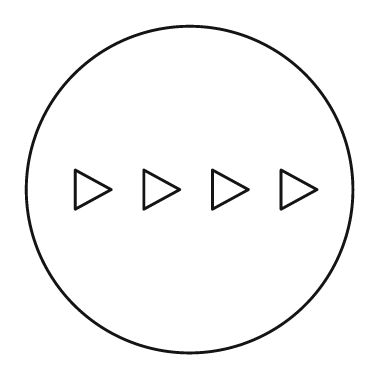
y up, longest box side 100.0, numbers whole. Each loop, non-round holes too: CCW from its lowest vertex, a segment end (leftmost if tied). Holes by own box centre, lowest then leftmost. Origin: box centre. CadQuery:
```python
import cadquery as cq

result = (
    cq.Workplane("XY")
    .moveTo(0.0, 0.0)
    .circle(50.0)
    .moveTo(-35.0, -6.0)
    .lineTo(-24.0, 0.0)
    .lineTo(-35.0, 6.0)
    .close()
    .moveTo(-14.0, -6.0)
    .lineTo(-3.0, 0.0)
    .lineTo(-14.0, 6.0)
    .close()
    .moveTo(7.0, -6.0)
    .lineTo(18.0, 0.0)
    .lineTo(7.0, 6.0)
    .close()
    .moveTo(28.0, -6.0)
    .lineTo(39.0, 0.0)
    .lineTo(28.0, 6.0)
    .close()
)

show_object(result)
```